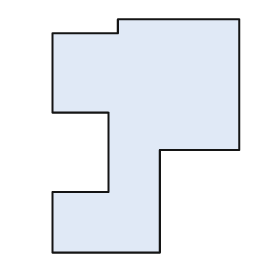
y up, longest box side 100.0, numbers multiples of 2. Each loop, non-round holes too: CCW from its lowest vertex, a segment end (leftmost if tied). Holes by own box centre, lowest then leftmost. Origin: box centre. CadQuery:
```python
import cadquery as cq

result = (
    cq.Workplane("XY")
    .moveTo(-40.0, -50.0)
    .lineTo(6.0, -50.0)
    .lineTo(6.0, -6.0)
    .lineTo(40.0, -6.0)
    .lineTo(40.0, 50.0)
    .lineTo(-12.0, 50.0)
    .lineTo(-12.0, 44.0)
    .lineTo(-40.0, 44.0)
    .lineTo(-40.0, 10.0)
    .lineTo(-16.0, 10.0)
    .lineTo(-16.0, -24.0)
    .lineTo(-40.0, -24.0)
    .close()
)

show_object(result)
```